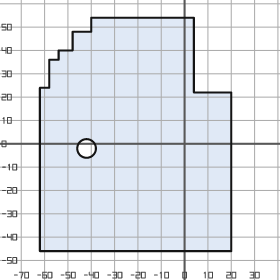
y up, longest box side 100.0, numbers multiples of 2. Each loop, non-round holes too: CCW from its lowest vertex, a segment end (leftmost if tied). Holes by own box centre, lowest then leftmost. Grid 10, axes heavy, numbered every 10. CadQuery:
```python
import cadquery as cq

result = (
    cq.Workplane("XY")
    .moveTo(-62.0, -46.0)
    .lineTo(20.0, -46.0)
    .lineTo(20.0, 22.0)
    .lineTo(4.0, 22.0)
    .lineTo(4.0, 54.0)
    .lineTo(-40.0, 54.0)
    .lineTo(-40.0, 48.0)
    .lineTo(-48.0, 48.0)
    .lineTo(-48.0, 40.0)
    .lineTo(-54.0, 40.0)
    .lineTo(-54.0, 36.0)
    .lineTo(-58.0, 36.0)
    .lineTo(-58.0, 24.0)
    .lineTo(-62.0, 24.0)
    .close()
    .moveTo(-42.0, -2.0)
    .circle(4.0)
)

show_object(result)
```